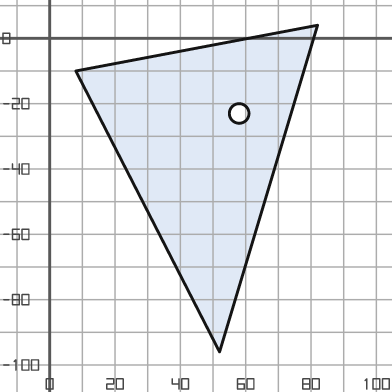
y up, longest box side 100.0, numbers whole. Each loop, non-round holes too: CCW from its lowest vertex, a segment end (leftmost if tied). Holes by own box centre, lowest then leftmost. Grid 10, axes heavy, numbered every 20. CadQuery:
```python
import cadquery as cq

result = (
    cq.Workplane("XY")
    .moveTo(52.0, -96.0)
    .lineTo(82.0, 4.0)
    .lineTo(8.0, -10.0)
    .close()
    .moveTo(58.0, -23.0)
    .circle(3.0)
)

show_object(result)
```